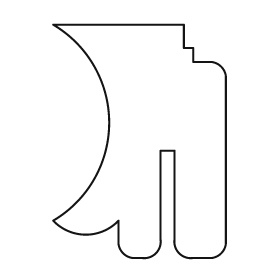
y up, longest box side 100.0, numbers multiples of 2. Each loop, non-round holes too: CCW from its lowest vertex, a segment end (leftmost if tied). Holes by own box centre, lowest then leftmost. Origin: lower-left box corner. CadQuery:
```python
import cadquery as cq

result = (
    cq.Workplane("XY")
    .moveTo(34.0, 0.0)
    .lineTo(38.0, 0.0)
    .threePointArc((44.0, 2.0), (46.0, 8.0))
    .lineTo(46.0, 46.0)
    .lineTo(52.0, 46.0)
    .lineTo(52.0, 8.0)
    .threePointArc((54.0, 2.0), (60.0, 0.0))
    .lineTo(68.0, 0.0)
    .threePointArc((72.0, 2.0), (74.0, 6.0))
    .lineTo(74.0, 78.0)
    .threePointArc((72.0, 82.0), (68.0, 84.0))
    .lineTo(60.0, 84.0)
    .lineTo(60.0, 90.0)
    .lineTo(56.0, 90.0)
    .lineTo(56.0, 100.0)
    .lineTo(0.0, 100.0)
    .threePointArc((24.0, 58.0), (0.0, 16.0))
    .threePointArc((14.0, 10.0), (28.0, 16.0))
    .lineTo(28.0, 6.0)
    .threePointArc((30.0, 2.0), (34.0, 0.0))
    .close()
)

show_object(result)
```